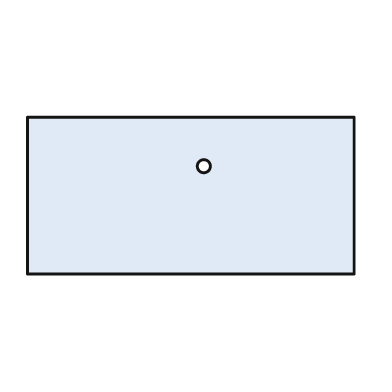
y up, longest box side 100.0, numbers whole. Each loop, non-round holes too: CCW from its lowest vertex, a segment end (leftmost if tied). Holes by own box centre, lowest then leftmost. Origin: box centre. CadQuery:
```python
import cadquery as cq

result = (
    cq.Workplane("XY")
    .moveTo(-50.0, -24.0)
    .lineTo(50.0, -24.0)
    .lineTo(50.0, 24.0)
    .lineTo(-50.0, 24.0)
    .close()
    .moveTo(4.0, 9.0)
    .circle(2.0)
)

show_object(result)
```